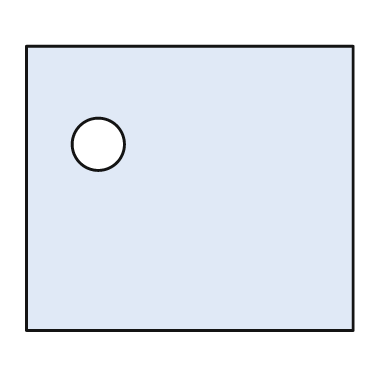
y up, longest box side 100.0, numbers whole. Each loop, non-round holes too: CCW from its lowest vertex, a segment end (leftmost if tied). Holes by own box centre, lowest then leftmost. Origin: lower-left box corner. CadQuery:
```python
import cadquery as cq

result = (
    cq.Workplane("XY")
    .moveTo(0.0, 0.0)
    .lineTo(100.0, 0.0)
    .lineTo(100.0, 87.0)
    .lineTo(0.0, 87.0)
    .close()
    .moveTo(22.0, 57.0)
    .circle(8.0)
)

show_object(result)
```